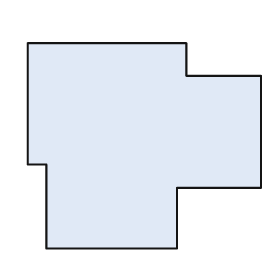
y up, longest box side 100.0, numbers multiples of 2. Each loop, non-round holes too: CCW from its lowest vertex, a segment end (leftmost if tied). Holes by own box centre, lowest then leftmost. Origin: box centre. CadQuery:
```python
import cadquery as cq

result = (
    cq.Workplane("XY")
    .moveTo(-42.0, -44.0)
    .lineTo(14.0, -44.0)
    .lineTo(14.0, -18.0)
    .lineTo(50.0, -18.0)
    .lineTo(50.0, 30.0)
    .lineTo(18.0, 30.0)
    .lineTo(18.0, 44.0)
    .lineTo(-50.0, 44.0)
    .lineTo(-50.0, -8.0)
    .lineTo(-42.0, -8.0)
    .close()
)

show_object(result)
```